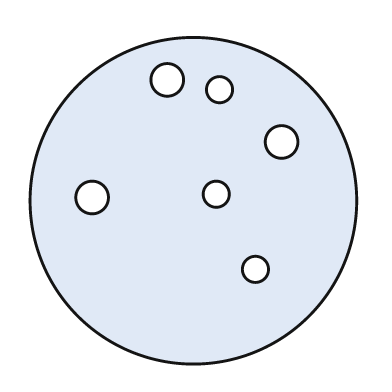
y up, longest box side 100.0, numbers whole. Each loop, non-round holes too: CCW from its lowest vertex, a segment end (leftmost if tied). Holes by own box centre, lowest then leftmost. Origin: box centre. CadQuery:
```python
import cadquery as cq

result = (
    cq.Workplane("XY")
    .moveTo(0.0, 0.0)
    .circle(50.0)
    .moveTo(19.0, -21.0)
    .circle(4.0)
    .moveTo(-31.0, 1.0)
    .circle(5.0)
    .moveTo(7.0, 2.0)
    .circle(4.0)
    .moveTo(27.0, 18.0)
    .circle(5.0)
    .moveTo(8.0, 34.0)
    .circle(4.0)
    .moveTo(-8.0, 37.0)
    .circle(5.0)
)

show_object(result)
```